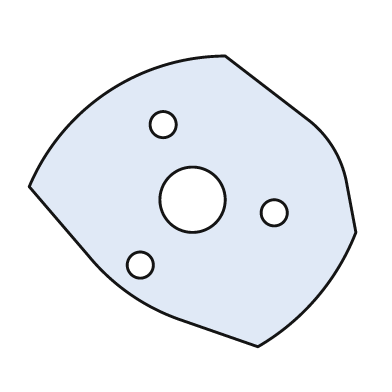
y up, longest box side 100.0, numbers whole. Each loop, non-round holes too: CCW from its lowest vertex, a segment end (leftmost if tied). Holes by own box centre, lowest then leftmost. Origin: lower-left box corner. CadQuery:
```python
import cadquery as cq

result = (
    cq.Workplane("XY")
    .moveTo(70.0, 0.0)
    .threePointArc((88.0, 15.0), (100.0, 35.0))
    .lineTo(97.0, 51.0)
    .threePointArc((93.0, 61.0), (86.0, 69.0))
    .lineTo(60.0, 89.0)
    .threePointArc((24.0, 78.0), (0.0, 49.0))
    .lineTo(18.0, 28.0)
    .threePointArc((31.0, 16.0), (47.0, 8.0))
    .close()
    .moveTo(34.0, 25.0)
    .circle(4.0)
    .moveTo(75.0, 41.0)
    .circle(4.0)
    .moveTo(50.0, 45.0)
    .circle(10.0)
    .moveTo(41.0, 68.0)
    .circle(4.0)
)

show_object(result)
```